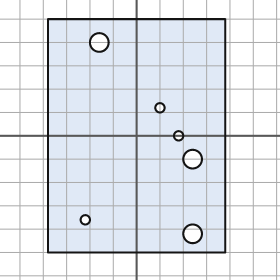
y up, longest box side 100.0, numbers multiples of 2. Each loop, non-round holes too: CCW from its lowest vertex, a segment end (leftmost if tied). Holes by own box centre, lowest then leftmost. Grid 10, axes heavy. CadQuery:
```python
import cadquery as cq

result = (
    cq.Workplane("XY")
    .moveTo(-38.0, -50.0)
    .lineTo(38.0, -50.0)
    .lineTo(38.0, 50.0)
    .lineTo(-38.0, 50.0)
    .close()
    .moveTo(24.0, -42.0)
    .circle(4.0)
    .moveTo(-22.0, -36.0)
    .circle(2.0)
    .moveTo(24.0, -10.0)
    .circle(4.0)
    .moveTo(18.0, 0.0)
    .circle(2.0)
    .moveTo(10.0, 12.0)
    .circle(2.0)
    .moveTo(-16.0, 40.0)
    .circle(4.0)
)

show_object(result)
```